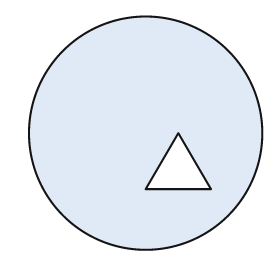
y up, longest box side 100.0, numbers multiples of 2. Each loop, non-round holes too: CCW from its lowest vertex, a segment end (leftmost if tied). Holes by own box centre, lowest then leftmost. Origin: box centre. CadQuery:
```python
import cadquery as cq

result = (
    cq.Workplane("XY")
    .moveTo(0.0, 0.0)
    .circle(50.0)
    .moveTo(0.0, -24.0)
    .lineTo(28.0, -24.0)
    .lineTo(14.0, 0.0)
    .close()
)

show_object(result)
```